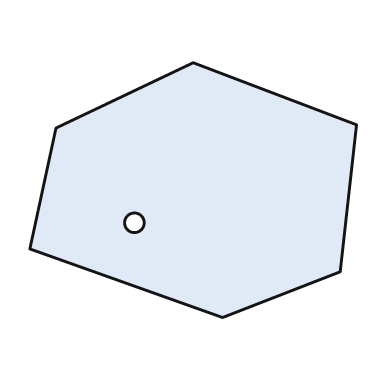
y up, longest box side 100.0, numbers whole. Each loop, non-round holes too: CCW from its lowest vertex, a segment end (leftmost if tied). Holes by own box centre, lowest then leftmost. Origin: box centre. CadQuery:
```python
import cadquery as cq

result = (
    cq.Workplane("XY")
    .moveTo(9.0, -39.0)
    .lineTo(45.0, -25.0)
    .lineTo(50.0, 20.0)
    .lineTo(0.0, 39.0)
    .lineTo(-42.0, 19.0)
    .lineTo(-50.0, -18.0)
    .close()
    .moveTo(-18.0, -10.0)
    .circle(3.0)
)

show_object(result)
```